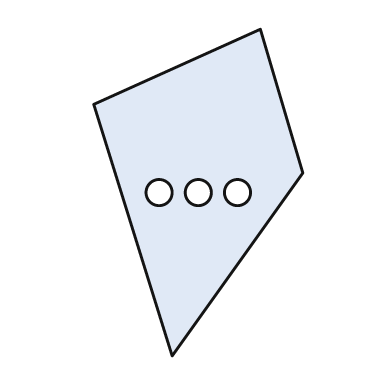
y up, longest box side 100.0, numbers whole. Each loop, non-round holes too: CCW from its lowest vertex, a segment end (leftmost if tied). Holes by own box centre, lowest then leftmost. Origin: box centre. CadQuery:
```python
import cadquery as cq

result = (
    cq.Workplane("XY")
    .moveTo(-8.0, -50.0)
    .lineTo(32.0, 6.0)
    .lineTo(19.0, 50.0)
    .lineTo(-32.0, 27.0)
    .close()
    .moveTo(-12.0, 0.0)
    .circle(4.0)
    .moveTo(0.0, 0.0)
    .circle(4.0)
    .moveTo(12.0, 0.0)
    .circle(4.0)
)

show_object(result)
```